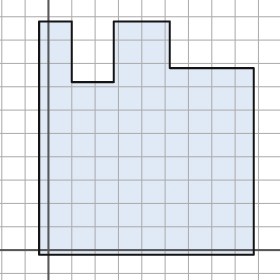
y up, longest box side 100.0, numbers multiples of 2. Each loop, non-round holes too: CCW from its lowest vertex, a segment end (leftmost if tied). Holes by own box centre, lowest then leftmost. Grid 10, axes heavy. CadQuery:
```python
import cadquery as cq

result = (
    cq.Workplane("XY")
    .moveTo(-4.0, -2.0)
    .lineTo(88.0, -2.0)
    .lineTo(88.0, 78.0)
    .lineTo(52.0, 78.0)
    .lineTo(52.0, 98.0)
    .lineTo(28.0, 98.0)
    .lineTo(28.0, 72.0)
    .lineTo(10.0, 72.0)
    .lineTo(10.0, 98.0)
    .lineTo(-4.0, 98.0)
    .close()
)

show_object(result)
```